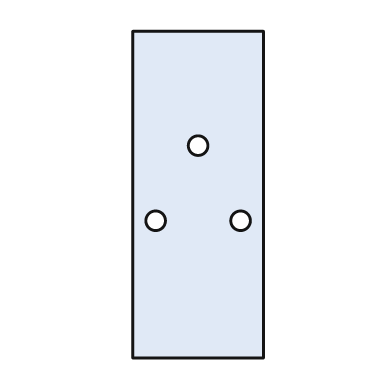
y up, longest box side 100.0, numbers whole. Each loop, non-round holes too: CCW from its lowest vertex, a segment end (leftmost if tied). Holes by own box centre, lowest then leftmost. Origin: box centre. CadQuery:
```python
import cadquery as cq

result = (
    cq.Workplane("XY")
    .moveTo(-20.0, -50.0)
    .lineTo(20.0, -50.0)
    .lineTo(20.0, 50.0)
    .lineTo(-20.0, 50.0)
    .close()
    .moveTo(-13.0, -8.0)
    .circle(3.0)
    .moveTo(13.0, -8.0)
    .circle(3.0)
    .moveTo(0.0, 15.0)
    .circle(3.0)
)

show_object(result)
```